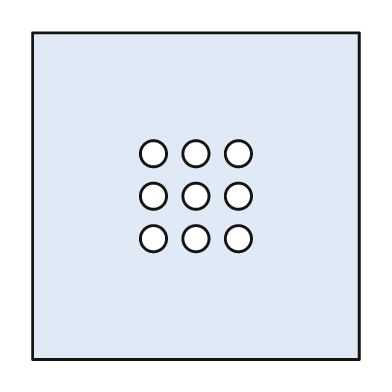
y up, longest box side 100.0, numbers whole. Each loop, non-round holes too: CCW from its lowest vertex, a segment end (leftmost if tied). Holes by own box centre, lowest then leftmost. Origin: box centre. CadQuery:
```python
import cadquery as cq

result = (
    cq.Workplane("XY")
    .moveTo(-50.0, -50.0)
    .lineTo(50.0, -50.0)
    .lineTo(50.0, 50.0)
    .lineTo(-50.0, 50.0)
    .close()
    .moveTo(-13.0, -13.0)
    .circle(4.0)
    .moveTo(0.0, -13.0)
    .circle(4.0)
    .moveTo(13.0, -13.0)
    .circle(4.0)
    .moveTo(-13.0, 0.0)
    .circle(4.0)
    .moveTo(0.0, 0.0)
    .circle(4.0)
    .moveTo(13.0, 0.0)
    .circle(4.0)
    .moveTo(-13.0, 13.0)
    .circle(4.0)
    .moveTo(0.0, 13.0)
    .circle(4.0)
    .moveTo(13.0, 13.0)
    .circle(4.0)
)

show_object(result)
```